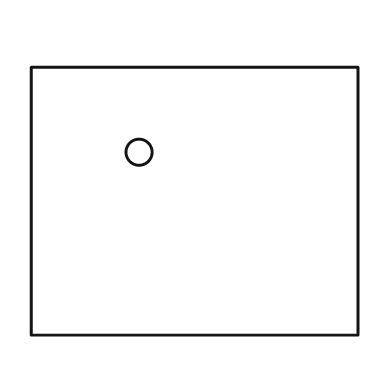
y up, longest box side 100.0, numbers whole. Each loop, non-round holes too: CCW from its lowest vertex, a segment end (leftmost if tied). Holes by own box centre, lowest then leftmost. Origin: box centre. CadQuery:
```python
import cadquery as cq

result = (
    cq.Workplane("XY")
    .moveTo(-50.0, -41.0)
    .lineTo(50.0, -41.0)
    .lineTo(50.0, 41.0)
    .lineTo(-50.0, 41.0)
    .close()
    .moveTo(-17.0, 15.0)
    .circle(4.0)
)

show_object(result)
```